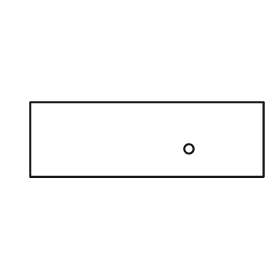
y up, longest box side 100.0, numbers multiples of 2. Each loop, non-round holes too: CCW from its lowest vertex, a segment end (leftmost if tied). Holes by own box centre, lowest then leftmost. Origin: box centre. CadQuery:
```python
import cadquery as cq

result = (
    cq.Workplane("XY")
    .moveTo(-50.0, -16.0)
    .lineTo(50.0, -16.0)
    .lineTo(50.0, 16.0)
    .lineTo(-50.0, 16.0)
    .close()
    .moveTo(18.0, -4.0)
    .circle(2.0)
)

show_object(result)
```